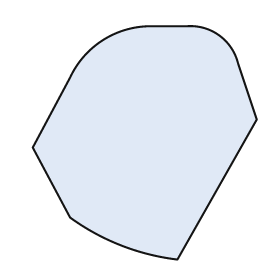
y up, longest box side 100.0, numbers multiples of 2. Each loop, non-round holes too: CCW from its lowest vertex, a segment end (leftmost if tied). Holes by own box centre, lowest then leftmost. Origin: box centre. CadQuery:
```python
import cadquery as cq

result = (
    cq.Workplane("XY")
    .moveTo(14.0, -50.0)
    .lineTo(48.0, 10.0)
    .lineTo(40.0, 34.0)
    .threePointArc((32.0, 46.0), (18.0, 50.0))
    .lineTo(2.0, 50.0)
    .threePointArc((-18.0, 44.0), (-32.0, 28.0))
    .lineTo(-48.0, -2.0)
    .lineTo(-32.0, -32.0)
    .threePointArc((-10.0, -44.0), (14.0, -50.0))
    .close()
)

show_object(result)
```